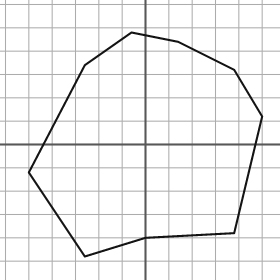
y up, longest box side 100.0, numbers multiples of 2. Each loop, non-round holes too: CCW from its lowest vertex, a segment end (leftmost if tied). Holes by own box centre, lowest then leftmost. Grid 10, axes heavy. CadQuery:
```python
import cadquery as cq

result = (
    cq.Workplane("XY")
    .moveTo(-26.0, -48.0)
    .lineTo(0.0, -40.0)
    .lineTo(38.0, -38.0)
    .lineTo(50.0, 12.0)
    .lineTo(38.0, 32.0)
    .lineTo(14.0, 44.0)
    .lineTo(-6.0, 48.0)
    .lineTo(-26.0, 34.0)
    .lineTo(-50.0, -12.0)
    .close()
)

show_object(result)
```